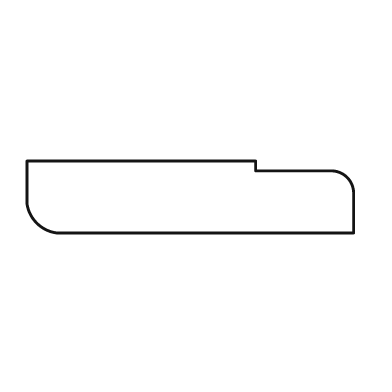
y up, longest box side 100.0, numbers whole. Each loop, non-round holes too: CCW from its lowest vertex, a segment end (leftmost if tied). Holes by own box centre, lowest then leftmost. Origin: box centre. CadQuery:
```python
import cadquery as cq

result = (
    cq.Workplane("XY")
    .moveTo(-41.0, -11.0)
    .lineTo(50.0, -11.0)
    .lineTo(50.0, 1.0)
    .threePointArc((48.0, 6.0), (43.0, 8.0))
    .lineTo(20.0, 8.0)
    .lineTo(20.0, 11.0)
    .lineTo(-50.0, 11.0)
    .lineTo(-50.0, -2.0)
    .threePointArc((-47.0, -8.0), (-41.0, -11.0))
    .close()
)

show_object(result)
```